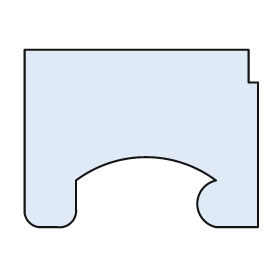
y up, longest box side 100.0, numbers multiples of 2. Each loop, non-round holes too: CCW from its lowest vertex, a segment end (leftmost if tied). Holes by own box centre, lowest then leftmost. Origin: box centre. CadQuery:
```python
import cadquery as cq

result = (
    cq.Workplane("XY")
    .moveTo(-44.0, -38.0)
    .lineTo(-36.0, -38.0)
    .threePointArc((-30.0, -36.0), (-28.0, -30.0))
    .lineTo(-28.0, -18.0)
    .threePointArc((2.0, -8.0), (32.0, -18.0))
    .threePointArc((24.0, -28.0), (32.0, -38.0))
    .lineTo(50.0, -38.0)
    .lineTo(50.0, 24.0)
    .lineTo(46.0, 24.0)
    .lineTo(46.0, 38.0)
    .lineTo(-50.0, 38.0)
    .lineTo(-50.0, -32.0)
    .threePointArc((-48.0, -36.0), (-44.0, -38.0))
    .close()
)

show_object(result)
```